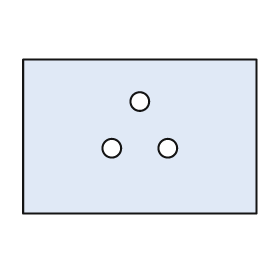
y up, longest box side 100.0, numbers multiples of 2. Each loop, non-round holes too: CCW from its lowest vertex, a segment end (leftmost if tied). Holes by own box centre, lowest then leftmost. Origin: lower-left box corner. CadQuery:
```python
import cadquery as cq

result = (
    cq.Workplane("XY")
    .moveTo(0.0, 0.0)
    .lineTo(100.0, 0.0)
    .lineTo(100.0, 66.0)
    .lineTo(0.0, 66.0)
    .close()
    .moveTo(38.0, 28.0)
    .circle(4.0)
    .moveTo(62.0, 28.0)
    .circle(4.0)
    .moveTo(50.0, 48.0)
    .circle(4.0)
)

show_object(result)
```